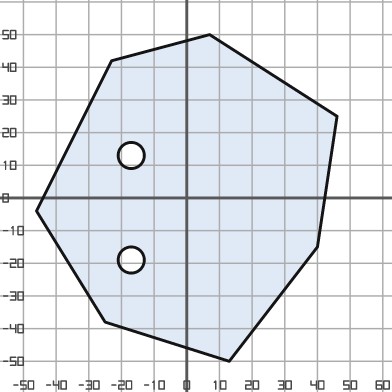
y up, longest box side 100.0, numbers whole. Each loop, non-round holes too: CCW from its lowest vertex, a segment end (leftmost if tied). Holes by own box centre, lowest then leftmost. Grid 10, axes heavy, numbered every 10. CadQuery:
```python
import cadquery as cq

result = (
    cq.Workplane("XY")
    .moveTo(13.0, -50.0)
    .lineTo(40.0, -15.0)
    .lineTo(46.0, 25.0)
    .lineTo(7.0, 50.0)
    .lineTo(-23.0, 42.0)
    .lineTo(-46.0, -4.0)
    .lineTo(-25.0, -38.0)
    .close()
    .moveTo(-17.0, -19.0)
    .circle(4.0)
    .moveTo(-17.0, 13.0)
    .circle(4.0)
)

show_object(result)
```